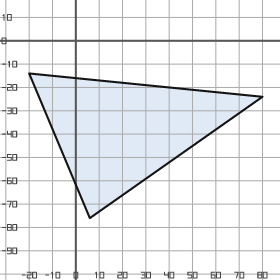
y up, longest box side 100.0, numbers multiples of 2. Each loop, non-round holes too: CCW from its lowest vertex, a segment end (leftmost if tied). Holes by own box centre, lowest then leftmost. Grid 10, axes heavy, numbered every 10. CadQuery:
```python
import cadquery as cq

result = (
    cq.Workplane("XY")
    .moveTo(6.0, -76.0)
    .lineTo(80.0, -24.0)
    .lineTo(-20.0, -14.0)
    .close()
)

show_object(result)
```